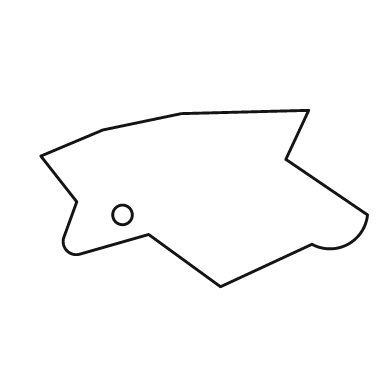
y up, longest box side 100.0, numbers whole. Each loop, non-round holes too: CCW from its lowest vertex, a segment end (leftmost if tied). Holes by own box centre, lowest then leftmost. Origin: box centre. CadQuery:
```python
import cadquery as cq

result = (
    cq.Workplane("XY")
    .moveTo(5.0, -27.0)
    .lineTo(33.0, -14.0)
    .threePointArc((44.0, -14.0), (50.0, -5.0))
    .lineTo(25.0, 12.0)
    .lineTo(32.0, 27.0)
    .lineTo(-7.0, 26.0)
    .lineTo(-31.0, 21.0)
    .lineTo(-50.0, 13.0)
    .lineTo(-39.0, -1.0)
    .lineTo(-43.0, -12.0)
    .threePointArc((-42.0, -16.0), (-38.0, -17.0))
    .lineTo(-17.0, -11.0)
    .close()
    .moveTo(-25.0, -5.0)
    .circle(3.0)
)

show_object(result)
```